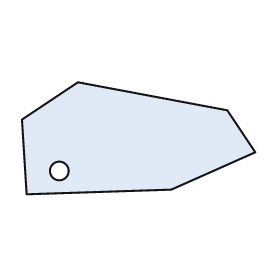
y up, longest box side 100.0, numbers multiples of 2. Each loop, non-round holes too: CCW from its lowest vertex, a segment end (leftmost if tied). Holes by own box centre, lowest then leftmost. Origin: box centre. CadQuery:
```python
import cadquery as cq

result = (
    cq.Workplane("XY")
    .moveTo(-48.0, -24.0)
    .lineTo(14.0, -22.0)
    .lineTo(50.0, -6.0)
    .lineTo(38.0, 12.0)
    .lineTo(-26.0, 24.0)
    .lineTo(-50.0, 8.0)
    .close()
    .moveTo(-34.0, -14.0)
    .circle(4.0)
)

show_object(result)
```